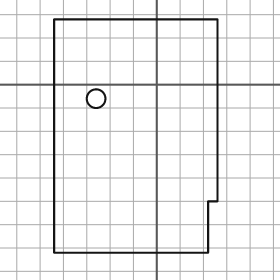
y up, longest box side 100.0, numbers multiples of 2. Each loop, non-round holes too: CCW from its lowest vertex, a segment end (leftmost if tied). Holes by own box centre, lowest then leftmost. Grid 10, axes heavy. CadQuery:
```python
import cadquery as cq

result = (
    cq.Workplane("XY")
    .moveTo(-44.0, -72.0)
    .lineTo(22.0, -72.0)
    .lineTo(22.0, -50.0)
    .lineTo(26.0, -50.0)
    .lineTo(26.0, 28.0)
    .lineTo(-44.0, 28.0)
    .close()
    .moveTo(-26.0, -6.0)
    .circle(4.0)
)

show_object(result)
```